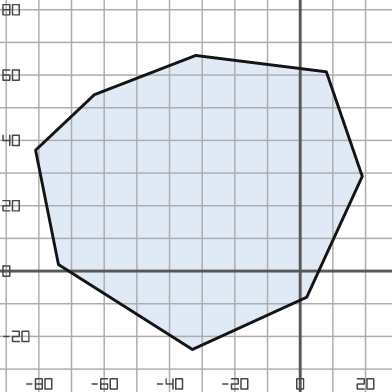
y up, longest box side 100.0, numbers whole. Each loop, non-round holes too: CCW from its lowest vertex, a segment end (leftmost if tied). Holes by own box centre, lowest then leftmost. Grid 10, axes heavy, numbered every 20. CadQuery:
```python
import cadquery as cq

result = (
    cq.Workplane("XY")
    .moveTo(-33.0, -24.0)
    .lineTo(2.0, -8.0)
    .lineTo(19.0, 29.0)
    .lineTo(8.0, 61.0)
    .lineTo(-32.0, 66.0)
    .lineTo(-63.0, 54.0)
    .lineTo(-81.0, 37.0)
    .lineTo(-74.0, 2.0)
    .close()
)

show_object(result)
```